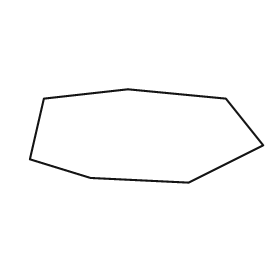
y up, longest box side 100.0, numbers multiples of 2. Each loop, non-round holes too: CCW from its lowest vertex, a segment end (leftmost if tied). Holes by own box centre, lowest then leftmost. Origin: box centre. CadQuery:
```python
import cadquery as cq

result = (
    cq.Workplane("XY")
    .moveTo(18.0, -20.0)
    .lineTo(50.0, -4.0)
    .lineTo(34.0, 16.0)
    .lineTo(-8.0, 20.0)
    .lineTo(-44.0, 16.0)
    .lineTo(-50.0, -10.0)
    .lineTo(-24.0, -18.0)
    .close()
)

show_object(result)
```